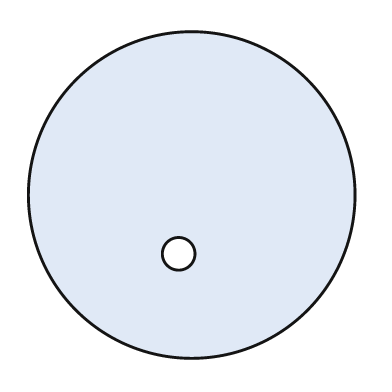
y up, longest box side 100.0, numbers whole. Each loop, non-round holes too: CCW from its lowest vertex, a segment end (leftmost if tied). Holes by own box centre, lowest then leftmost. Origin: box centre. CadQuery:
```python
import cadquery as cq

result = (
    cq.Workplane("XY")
    .moveTo(0.0, 0.0)
    .circle(50.0)
    .moveTo(-4.0, -18.0)
    .circle(5.0)
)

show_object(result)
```